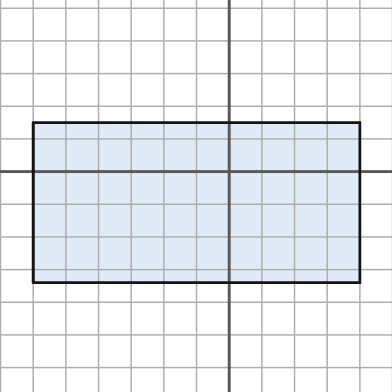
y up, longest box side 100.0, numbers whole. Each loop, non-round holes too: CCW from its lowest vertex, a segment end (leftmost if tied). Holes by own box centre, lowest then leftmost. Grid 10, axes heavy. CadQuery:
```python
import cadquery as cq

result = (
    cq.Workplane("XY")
    .moveTo(-60.0, -34.0)
    .lineTo(40.0, -34.0)
    .lineTo(40.0, 15.0)
    .lineTo(-60.0, 15.0)
    .close()
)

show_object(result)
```